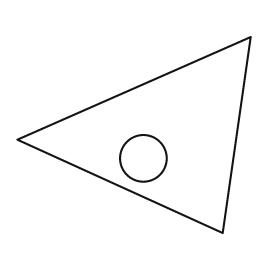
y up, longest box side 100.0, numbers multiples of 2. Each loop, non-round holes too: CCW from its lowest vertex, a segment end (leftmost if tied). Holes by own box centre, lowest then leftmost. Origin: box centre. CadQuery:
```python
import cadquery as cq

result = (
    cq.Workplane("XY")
    .moveTo(38.0, -42.0)
    .lineTo(50.0, 42.0)
    .lineTo(-50.0, -2.0)
    .close()
    .moveTo(4.0, -10.0)
    .circle(10.0)
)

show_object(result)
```